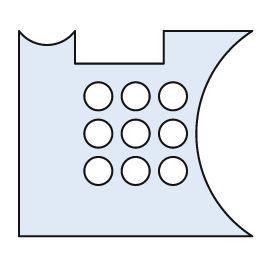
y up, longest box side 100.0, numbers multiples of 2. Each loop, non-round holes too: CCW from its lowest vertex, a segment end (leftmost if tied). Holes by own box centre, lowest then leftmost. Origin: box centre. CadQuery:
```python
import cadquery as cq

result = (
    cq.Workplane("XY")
    .moveTo(-50.0, -44.0)
    .lineTo(50.0, -44.0)
    .threePointArc((26.0, 0.0), (50.0, 44.0))
    .lineTo(12.0, 44.0)
    .lineTo(12.0, 30.0)
    .lineTo(-26.0, 30.0)
    .lineTo(-26.0, 44.0)
    .threePointArc((-38.0, 38.0), (-50.0, 44.0))
    .close()
    .moveTo(-16.0, -16.0)
    .circle(6.0)
    .moveTo(0.0, -16.0)
    .circle(6.0)
    .moveTo(16.0, -16.0)
    .circle(6.0)
    .moveTo(-16.0, 0.0)
    .circle(6.0)
    .moveTo(0.0, 0.0)
    .circle(6.0)
    .moveTo(16.0, 0.0)
    .circle(6.0)
    .moveTo(-16.0, 16.0)
    .circle(6.0)
    .moveTo(0.0, 16.0)
    .circle(6.0)
    .moveTo(16.0, 16.0)
    .circle(6.0)
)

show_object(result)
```